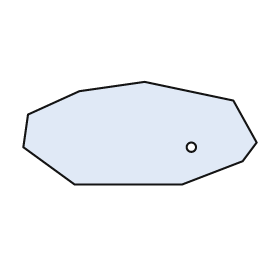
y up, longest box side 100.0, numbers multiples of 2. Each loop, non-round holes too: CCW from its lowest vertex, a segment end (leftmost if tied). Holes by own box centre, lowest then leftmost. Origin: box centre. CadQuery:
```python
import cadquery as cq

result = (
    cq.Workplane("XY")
    .moveTo(-28.0, -22.0)
    .lineTo(18.0, -22.0)
    .lineTo(44.0, -12.0)
    .lineTo(50.0, -4.0)
    .lineTo(40.0, 14.0)
    .lineTo(2.0, 22.0)
    .lineTo(-26.0, 18.0)
    .lineTo(-48.0, 8.0)
    .lineTo(-50.0, -6.0)
    .close()
    .moveTo(22.0, -6.0)
    .circle(2.0)
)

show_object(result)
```